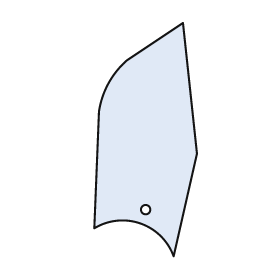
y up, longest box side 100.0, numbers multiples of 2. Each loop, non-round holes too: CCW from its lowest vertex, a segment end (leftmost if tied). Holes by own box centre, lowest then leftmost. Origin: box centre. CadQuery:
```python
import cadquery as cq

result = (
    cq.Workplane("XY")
    .moveTo(12.0, -50.0)
    .lineTo(22.0, -6.0)
    .lineTo(16.0, 50.0)
    .lineTo(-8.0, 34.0)
    .threePointArc((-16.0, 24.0), (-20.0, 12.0))
    .lineTo(-22.0, -38.0)
    .threePointArc((-2.0, -36.0), (12.0, -50.0))
    .close()
    .moveTo(0.0, -30.0)
    .circle(2.0)
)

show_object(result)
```